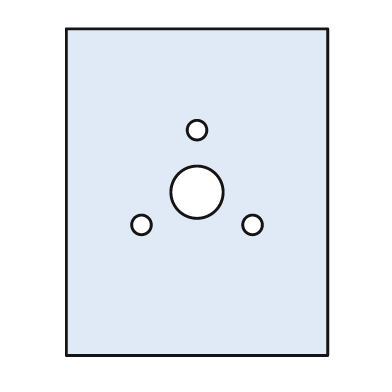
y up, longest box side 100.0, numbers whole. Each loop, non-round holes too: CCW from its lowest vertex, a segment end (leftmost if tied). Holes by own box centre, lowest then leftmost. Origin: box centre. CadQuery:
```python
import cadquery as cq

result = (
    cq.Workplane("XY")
    .moveTo(-40.0, -50.0)
    .lineTo(40.0, -50.0)
    .lineTo(40.0, 50.0)
    .lineTo(-40.0, 50.0)
    .close()
    .moveTo(-17.0, -10.0)
    .circle(3.0)
    .moveTo(17.0, -10.0)
    .circle(3.0)
    .moveTo(0.0, 0.0)
    .circle(8.0)
    .moveTo(0.0, 19.0)
    .circle(3.0)
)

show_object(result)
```